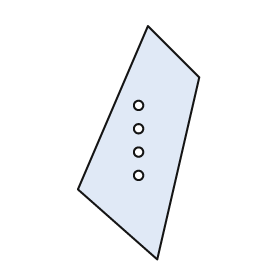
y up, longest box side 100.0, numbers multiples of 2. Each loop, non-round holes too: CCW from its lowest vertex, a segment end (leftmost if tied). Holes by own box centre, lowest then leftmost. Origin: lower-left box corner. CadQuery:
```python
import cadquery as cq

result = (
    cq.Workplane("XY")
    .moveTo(34.0, 0.0)
    .lineTo(52.0, 78.0)
    .lineTo(30.0, 100.0)
    .lineTo(0.0, 30.0)
    .close()
    .moveTo(26.0, 36.0)
    .circle(2.0)
    .moveTo(26.0, 46.0)
    .circle(2.0)
    .moveTo(26.0, 56.0)
    .circle(2.0)
    .moveTo(26.0, 66.0)
    .circle(2.0)
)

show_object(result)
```